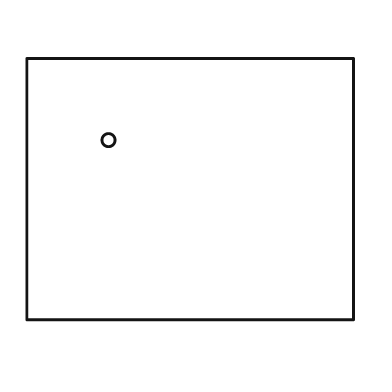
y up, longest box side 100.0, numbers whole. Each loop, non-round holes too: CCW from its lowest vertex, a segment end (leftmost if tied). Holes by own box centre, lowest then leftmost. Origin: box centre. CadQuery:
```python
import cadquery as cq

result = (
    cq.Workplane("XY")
    .moveTo(-50.0, -40.0)
    .lineTo(50.0, -40.0)
    .lineTo(50.0, 40.0)
    .lineTo(-50.0, 40.0)
    .close()
    .moveTo(-25.0, 15.0)
    .circle(2.0)
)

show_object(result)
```